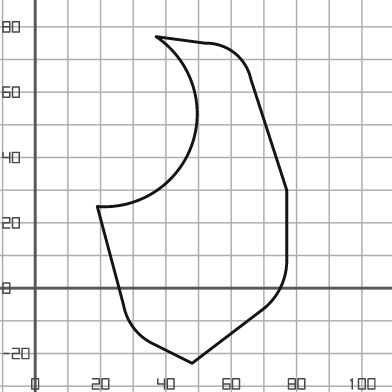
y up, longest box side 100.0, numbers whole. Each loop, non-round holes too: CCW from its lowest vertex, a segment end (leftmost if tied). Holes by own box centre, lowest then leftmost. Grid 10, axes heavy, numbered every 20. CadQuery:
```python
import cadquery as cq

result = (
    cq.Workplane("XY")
    .moveTo(48.0, -23.0)
    .lineTo(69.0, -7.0)
    .threePointArc((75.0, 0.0), (77.0, 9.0))
    .lineTo(77.0, 30.0)
    .lineTo(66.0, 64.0)
    .threePointArc((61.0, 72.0), (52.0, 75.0))
    .lineTo(37.0, 77.0)
    .threePointArc((48.0, 44.0), (19.0, 25.0))
    .lineTo(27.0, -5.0)
    .threePointArc((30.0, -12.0), (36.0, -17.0))
    .close()
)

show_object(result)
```